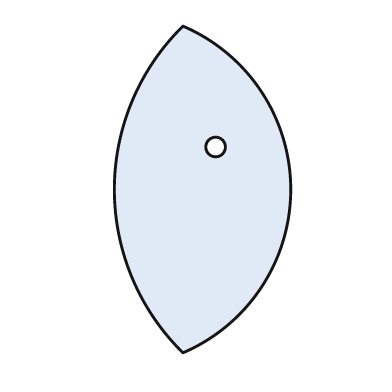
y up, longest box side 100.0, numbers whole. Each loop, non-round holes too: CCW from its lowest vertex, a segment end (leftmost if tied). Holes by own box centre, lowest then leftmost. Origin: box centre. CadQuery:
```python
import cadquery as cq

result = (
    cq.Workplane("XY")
    .moveTo(-6.0, -50.0)
    .threePointArc((27.0, 0.0), (-6.0, 50.0))
    .threePointArc((-27.0, 0.0), (-6.0, -50.0))
    .close()
    .moveTo(4.0, 13.0)
    .circle(3.0)
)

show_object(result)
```